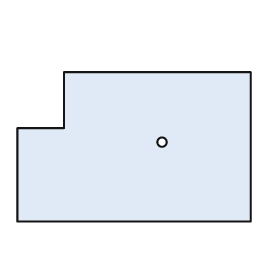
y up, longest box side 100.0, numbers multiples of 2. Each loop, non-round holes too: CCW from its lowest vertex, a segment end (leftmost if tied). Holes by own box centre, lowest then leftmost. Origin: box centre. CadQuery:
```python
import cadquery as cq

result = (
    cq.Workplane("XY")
    .moveTo(-50.0, -32.0)
    .lineTo(50.0, -32.0)
    .lineTo(50.0, 32.0)
    .lineTo(-30.0, 32.0)
    .lineTo(-30.0, 8.0)
    .lineTo(-50.0, 8.0)
    .close()
    .moveTo(12.0, 2.0)
    .circle(2.0)
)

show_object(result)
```